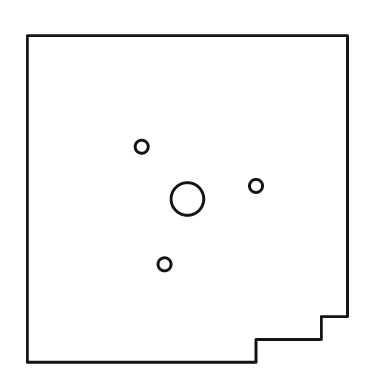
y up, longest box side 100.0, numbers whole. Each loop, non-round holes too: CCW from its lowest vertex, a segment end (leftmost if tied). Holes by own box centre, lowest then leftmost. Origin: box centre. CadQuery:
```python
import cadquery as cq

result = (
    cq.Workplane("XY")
    .moveTo(-49.0, -50.0)
    .lineTo(21.0, -50.0)
    .lineTo(21.0, -43.0)
    .lineTo(41.0, -43.0)
    .lineTo(41.0, -36.0)
    .lineTo(49.0, -36.0)
    .lineTo(49.0, 50.0)
    .lineTo(-49.0, 50.0)
    .close()
    .moveTo(-7.0, -20.0)
    .circle(2.0)
    .moveTo(0.0, 0.0)
    .circle(5.0)
    .moveTo(21.0, 4.0)
    .circle(2.0)
    .moveTo(-14.0, 16.0)
    .circle(2.0)
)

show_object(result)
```